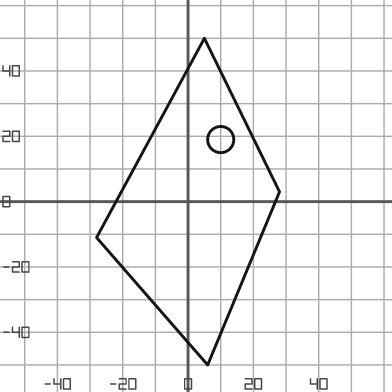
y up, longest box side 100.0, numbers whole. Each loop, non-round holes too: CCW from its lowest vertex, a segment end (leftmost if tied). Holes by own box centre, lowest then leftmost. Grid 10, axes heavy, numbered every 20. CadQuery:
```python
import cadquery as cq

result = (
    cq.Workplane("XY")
    .moveTo(6.0, -50.0)
    .lineTo(28.0, 3.0)
    .lineTo(5.0, 50.0)
    .lineTo(-28.0, -11.0)
    .close()
    .moveTo(10.0, 19.0)
    .circle(4.0)
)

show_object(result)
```